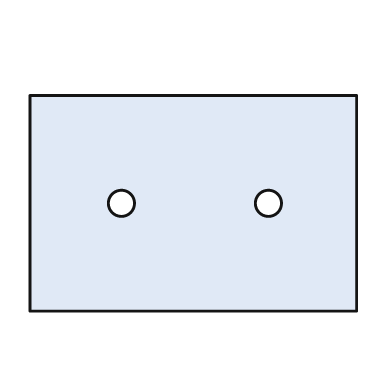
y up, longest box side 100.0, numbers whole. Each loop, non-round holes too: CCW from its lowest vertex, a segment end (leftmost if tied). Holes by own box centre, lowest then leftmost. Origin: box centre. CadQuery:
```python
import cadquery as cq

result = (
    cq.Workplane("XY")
    .moveTo(-50.0, -33.0)
    .lineTo(50.0, -33.0)
    .lineTo(50.0, 33.0)
    .lineTo(-50.0, 33.0)
    .close()
    .moveTo(-22.0, 0.0)
    .circle(4.0)
    .moveTo(23.0, 0.0)
    .circle(4.0)
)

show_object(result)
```